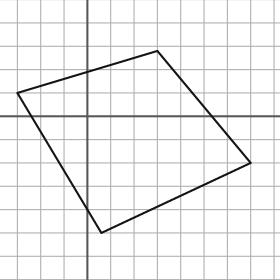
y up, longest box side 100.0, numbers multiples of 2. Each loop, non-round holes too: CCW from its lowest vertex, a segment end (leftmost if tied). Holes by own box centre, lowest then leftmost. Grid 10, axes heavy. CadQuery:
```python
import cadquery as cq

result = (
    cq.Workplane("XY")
    .moveTo(6.0, -50.0)
    .lineTo(70.0, -20.0)
    .lineTo(30.0, 28.0)
    .lineTo(-30.0, 10.0)
    .close()
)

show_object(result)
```